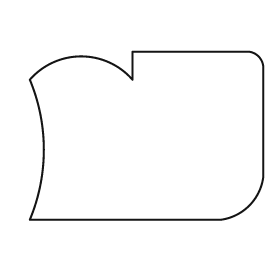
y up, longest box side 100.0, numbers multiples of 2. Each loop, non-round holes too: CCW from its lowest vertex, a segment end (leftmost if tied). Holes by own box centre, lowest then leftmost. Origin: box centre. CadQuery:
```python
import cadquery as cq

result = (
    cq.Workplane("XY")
    .moveTo(-50.0, -36.0)
    .lineTo(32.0, -36.0)
    .threePointArc((44.0, -30.0), (50.0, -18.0))
    .lineTo(50.0, 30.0)
    .threePointArc((48.0, 34.0), (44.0, 36.0))
    .lineTo(-6.0, 36.0)
    .lineTo(-6.0, 24.0)
    .threePointArc((-28.0, 34.0), (-50.0, 24.0))
    .threePointArc((-44.0, -6.0), (-50.0, -36.0))
    .close()
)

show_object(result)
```